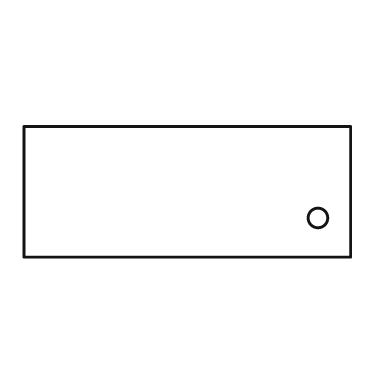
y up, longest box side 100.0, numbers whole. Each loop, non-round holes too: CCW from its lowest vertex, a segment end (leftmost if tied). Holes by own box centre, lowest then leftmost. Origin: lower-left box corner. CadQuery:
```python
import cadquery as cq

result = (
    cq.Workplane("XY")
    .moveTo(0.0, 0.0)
    .lineTo(100.0, 0.0)
    .lineTo(100.0, 40.0)
    .lineTo(0.0, 40.0)
    .close()
    .moveTo(90.0, 12.0)
    .circle(3.0)
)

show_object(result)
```